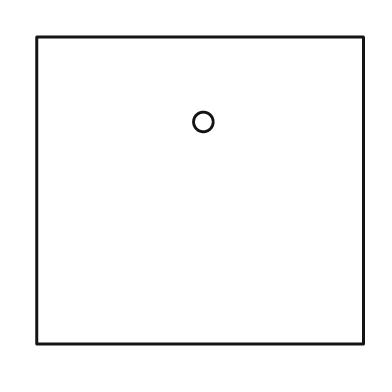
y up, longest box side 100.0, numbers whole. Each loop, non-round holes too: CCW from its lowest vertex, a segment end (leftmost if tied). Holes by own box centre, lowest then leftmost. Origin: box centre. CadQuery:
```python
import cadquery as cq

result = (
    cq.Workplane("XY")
    .moveTo(-50.0, -47.0)
    .lineTo(50.0, -47.0)
    .lineTo(50.0, 47.0)
    .lineTo(-50.0, 47.0)
    .close()
    .moveTo(1.0, 21.0)
    .circle(3.0)
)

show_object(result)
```